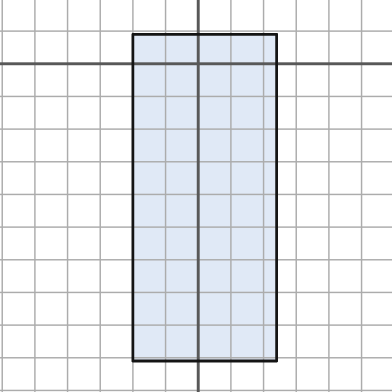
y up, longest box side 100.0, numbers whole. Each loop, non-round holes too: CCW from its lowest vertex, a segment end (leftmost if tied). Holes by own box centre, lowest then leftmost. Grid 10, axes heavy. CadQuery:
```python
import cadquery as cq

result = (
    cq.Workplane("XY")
    .moveTo(-20.0, -91.0)
    .lineTo(24.0, -91.0)
    .lineTo(24.0, 9.0)
    .lineTo(-20.0, 9.0)
    .close()
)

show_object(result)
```